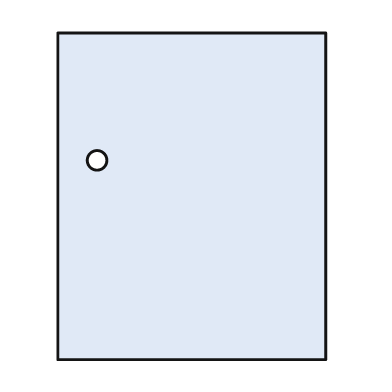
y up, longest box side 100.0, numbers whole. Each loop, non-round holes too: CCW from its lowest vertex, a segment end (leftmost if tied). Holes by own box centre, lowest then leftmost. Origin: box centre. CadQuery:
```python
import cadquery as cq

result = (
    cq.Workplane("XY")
    .moveTo(-41.0, -50.0)
    .lineTo(41.0, -50.0)
    .lineTo(41.0, 50.0)
    .lineTo(-41.0, 50.0)
    .close()
    .moveTo(-29.0, 11.0)
    .circle(3.0)
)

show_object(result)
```